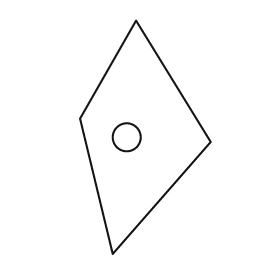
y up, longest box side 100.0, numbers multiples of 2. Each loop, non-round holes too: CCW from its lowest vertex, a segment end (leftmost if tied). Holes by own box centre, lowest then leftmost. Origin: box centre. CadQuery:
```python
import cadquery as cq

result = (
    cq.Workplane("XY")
    .moveTo(-14.0, -50.0)
    .lineTo(28.0, -2.0)
    .lineTo(-4.0, 50.0)
    .lineTo(-28.0, 8.0)
    .close()
    .moveTo(-8.0, 0.0)
    .circle(6.0)
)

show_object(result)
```